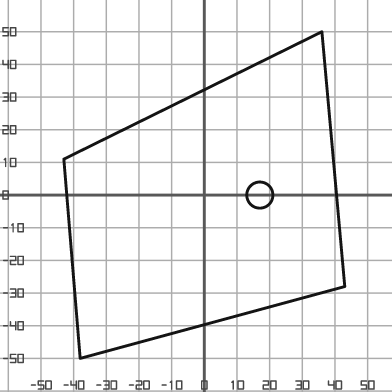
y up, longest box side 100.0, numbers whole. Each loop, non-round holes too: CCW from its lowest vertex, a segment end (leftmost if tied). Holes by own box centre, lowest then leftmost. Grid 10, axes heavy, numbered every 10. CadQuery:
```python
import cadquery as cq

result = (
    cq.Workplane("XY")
    .moveTo(-38.0, -50.0)
    .lineTo(43.0, -28.0)
    .lineTo(36.0, 50.0)
    .lineTo(-43.0, 11.0)
    .close()
    .moveTo(17.0, 0.0)
    .circle(4.0)
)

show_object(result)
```